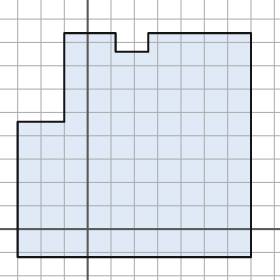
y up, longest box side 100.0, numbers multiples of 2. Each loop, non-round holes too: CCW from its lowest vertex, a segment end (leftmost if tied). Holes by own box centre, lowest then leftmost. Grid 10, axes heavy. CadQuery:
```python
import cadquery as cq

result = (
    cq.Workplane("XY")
    .moveTo(-30.0, -12.0)
    .lineTo(70.0, -12.0)
    .lineTo(70.0, 84.0)
    .lineTo(26.0, 84.0)
    .lineTo(26.0, 76.0)
    .lineTo(12.0, 76.0)
    .lineTo(12.0, 84.0)
    .lineTo(-10.0, 84.0)
    .lineTo(-10.0, 46.0)
    .lineTo(-30.0, 46.0)
    .close()
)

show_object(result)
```